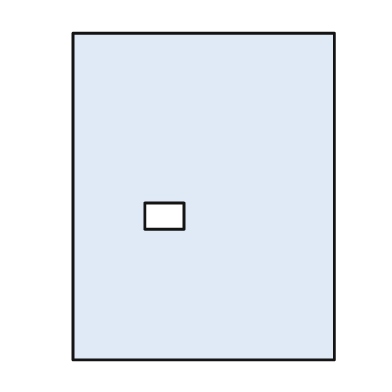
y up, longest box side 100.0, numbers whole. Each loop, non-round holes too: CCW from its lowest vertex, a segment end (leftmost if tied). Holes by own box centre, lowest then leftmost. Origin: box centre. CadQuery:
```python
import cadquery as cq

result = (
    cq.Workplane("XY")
    .moveTo(-40.0, -50.0)
    .lineTo(40.0, -50.0)
    .lineTo(40.0, 50.0)
    .lineTo(-40.0, 50.0)
    .close()
    .moveTo(-18.0, -10.0)
    .lineTo(-6.0, -10.0)
    .lineTo(-6.0, -2.0)
    .lineTo(-18.0, -2.0)
    .close()
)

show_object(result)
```